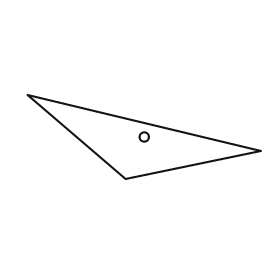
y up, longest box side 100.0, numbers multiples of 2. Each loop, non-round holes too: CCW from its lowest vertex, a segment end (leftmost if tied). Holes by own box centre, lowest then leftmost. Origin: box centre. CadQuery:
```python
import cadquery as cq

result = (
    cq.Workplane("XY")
    .moveTo(-8.0, -18.0)
    .lineTo(50.0, -6.0)
    .lineTo(-50.0, 18.0)
    .close()
    .moveTo(0.0, 0.0)
    .circle(2.0)
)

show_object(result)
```